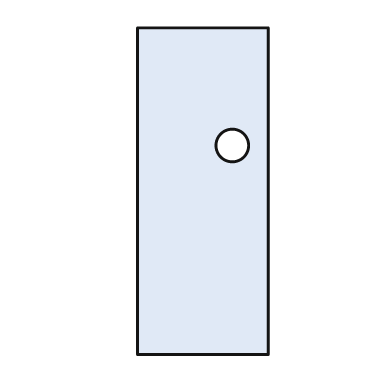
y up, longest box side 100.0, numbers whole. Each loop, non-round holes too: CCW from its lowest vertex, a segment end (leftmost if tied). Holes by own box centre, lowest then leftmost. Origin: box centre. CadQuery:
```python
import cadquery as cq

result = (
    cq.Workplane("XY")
    .moveTo(-20.0, -50.0)
    .lineTo(20.0, -50.0)
    .lineTo(20.0, 50.0)
    .lineTo(-20.0, 50.0)
    .close()
    .moveTo(9.0, 14.0)
    .circle(5.0)
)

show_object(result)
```